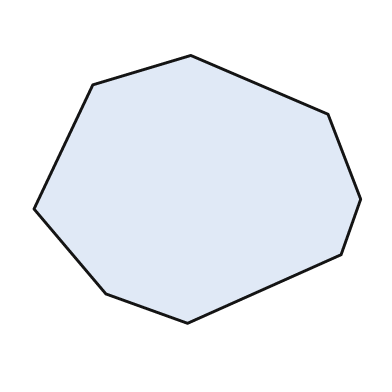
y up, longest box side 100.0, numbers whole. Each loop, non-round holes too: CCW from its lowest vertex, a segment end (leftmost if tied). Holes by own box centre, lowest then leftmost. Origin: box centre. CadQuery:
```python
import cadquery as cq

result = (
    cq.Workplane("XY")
    .moveTo(-3.0, -41.0)
    .lineTo(44.0, -20.0)
    .lineTo(50.0, -3.0)
    .lineTo(40.0, 23.0)
    .lineTo(-2.0, 41.0)
    .lineTo(-32.0, 32.0)
    .lineTo(-50.0, -6.0)
    .lineTo(-28.0, -32.0)
    .close()
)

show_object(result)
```